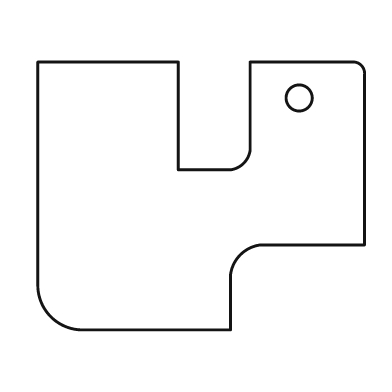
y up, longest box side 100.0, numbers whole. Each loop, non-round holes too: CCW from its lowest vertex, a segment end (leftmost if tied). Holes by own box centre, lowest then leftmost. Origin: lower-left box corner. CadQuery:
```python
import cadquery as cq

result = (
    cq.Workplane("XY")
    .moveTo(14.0, 0.0)
    .lineTo(59.0, 0.0)
    .lineTo(59.0, 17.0)
    .threePointArc((62.0, 23.0), (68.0, 26.0))
    .lineTo(100.0, 26.0)
    .lineTo(100.0, 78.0)
    .threePointArc((99.0, 81.0), (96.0, 82.0))
    .lineTo(65.0, 82.0)
    .lineTo(65.0, 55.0)
    .threePointArc((63.0, 51.0), (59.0, 49.0))
    .lineTo(43.0, 49.0)
    .lineTo(43.0, 82.0)
    .lineTo(0.0, 82.0)
    .lineTo(0.0, 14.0)
    .threePointArc((4.0, 4.0), (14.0, 0.0))
    .close()
    .moveTo(80.0, 71.0)
    .circle(4.0)
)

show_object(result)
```